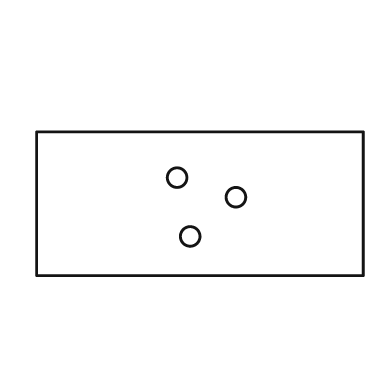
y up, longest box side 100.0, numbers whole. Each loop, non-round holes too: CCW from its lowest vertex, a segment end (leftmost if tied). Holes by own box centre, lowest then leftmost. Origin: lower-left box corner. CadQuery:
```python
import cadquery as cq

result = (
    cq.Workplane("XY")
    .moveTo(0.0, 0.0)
    .lineTo(100.0, 0.0)
    .lineTo(100.0, 44.0)
    .lineTo(0.0, 44.0)
    .close()
    .moveTo(47.0, 12.0)
    .circle(3.0)
    .moveTo(61.0, 24.0)
    .circle(3.0)
    .moveTo(43.0, 30.0)
    .circle(3.0)
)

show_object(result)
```